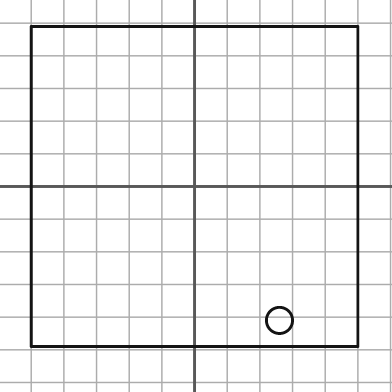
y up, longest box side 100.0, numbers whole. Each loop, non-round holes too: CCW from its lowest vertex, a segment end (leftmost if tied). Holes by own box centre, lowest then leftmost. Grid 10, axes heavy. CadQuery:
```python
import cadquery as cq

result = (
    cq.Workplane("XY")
    .moveTo(-50.0, -49.0)
    .lineTo(50.0, -49.0)
    .lineTo(50.0, 49.0)
    .lineTo(-50.0, 49.0)
    .close()
    .moveTo(26.0, -41.0)
    .circle(4.0)
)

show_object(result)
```